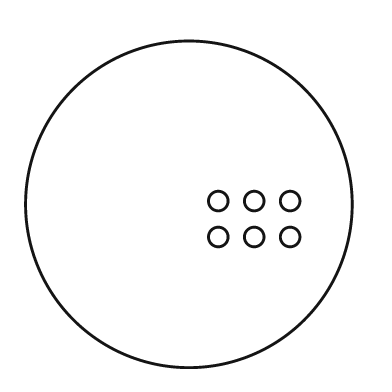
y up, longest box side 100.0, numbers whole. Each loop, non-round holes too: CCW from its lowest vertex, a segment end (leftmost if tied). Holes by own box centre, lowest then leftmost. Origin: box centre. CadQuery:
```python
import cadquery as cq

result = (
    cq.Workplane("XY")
    .moveTo(0.0, 0.0)
    .circle(50.0)
    .moveTo(9.0, -10.0)
    .circle(3.0)
    .moveTo(20.0, -10.0)
    .circle(3.0)
    .moveTo(31.0, -10.0)
    .circle(3.0)
    .moveTo(9.0, 1.0)
    .circle(3.0)
    .moveTo(20.0, 1.0)
    .circle(3.0)
    .moveTo(31.0, 1.0)
    .circle(3.0)
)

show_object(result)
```